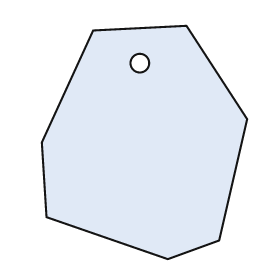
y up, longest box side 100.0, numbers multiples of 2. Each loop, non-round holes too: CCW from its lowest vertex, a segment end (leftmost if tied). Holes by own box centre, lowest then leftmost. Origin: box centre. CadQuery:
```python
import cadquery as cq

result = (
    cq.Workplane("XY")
    .moveTo(10.0, -50.0)
    .lineTo(32.0, -42.0)
    .lineTo(44.0, 10.0)
    .lineTo(18.0, 50.0)
    .lineTo(-22.0, 48.0)
    .lineTo(-44.0, 0.0)
    .lineTo(-42.0, -32.0)
    .close()
    .moveTo(-2.0, 34.0)
    .circle(4.0)
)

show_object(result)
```